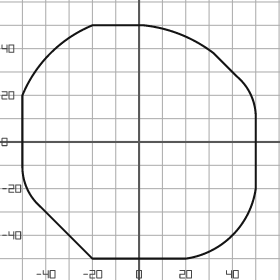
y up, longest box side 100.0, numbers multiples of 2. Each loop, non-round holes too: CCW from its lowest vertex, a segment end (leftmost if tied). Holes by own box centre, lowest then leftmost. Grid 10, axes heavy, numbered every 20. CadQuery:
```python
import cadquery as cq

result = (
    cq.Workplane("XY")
    .moveTo(-20.0, -50.0)
    .lineTo(20.0, -50.0)
    .threePointArc((40.0, -40.0), (50.0, -20.0))
    .lineTo(50.0, 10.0)
    .threePointArc((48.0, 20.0), (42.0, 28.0))
    .lineTo(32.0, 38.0)
    .threePointArc((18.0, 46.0), (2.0, 50.0))
    .lineTo(-20.0, 50.0)
    .threePointArc((-38.0, 38.0), (-50.0, 20.0))
    .lineTo(-50.0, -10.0)
    .threePointArc((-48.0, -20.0), (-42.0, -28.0))
    .close()
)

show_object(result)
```